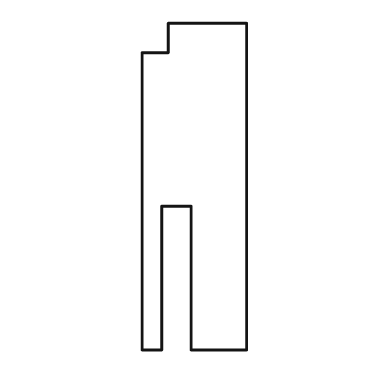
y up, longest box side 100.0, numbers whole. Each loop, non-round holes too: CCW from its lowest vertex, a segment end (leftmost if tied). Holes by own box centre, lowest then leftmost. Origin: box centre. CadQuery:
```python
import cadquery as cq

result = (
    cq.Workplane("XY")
    .moveTo(-16.0, -50.0)
    .lineTo(-10.0, -50.0)
    .lineTo(-10.0, -6.0)
    .lineTo(-1.0, -6.0)
    .lineTo(-1.0, -50.0)
    .lineTo(16.0, -50.0)
    .lineTo(16.0, 50.0)
    .lineTo(-8.0, 50.0)
    .lineTo(-8.0, 41.0)
    .lineTo(-16.0, 41.0)
    .close()
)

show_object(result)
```